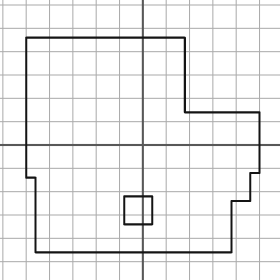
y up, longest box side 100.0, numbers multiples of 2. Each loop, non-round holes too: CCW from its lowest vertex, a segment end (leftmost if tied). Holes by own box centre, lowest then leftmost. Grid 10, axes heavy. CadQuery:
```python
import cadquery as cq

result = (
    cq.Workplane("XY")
    .moveTo(-46.0, -46.0)
    .lineTo(38.0, -46.0)
    .lineTo(38.0, -24.0)
    .lineTo(46.0, -24.0)
    .lineTo(46.0, -12.0)
    .lineTo(50.0, -12.0)
    .lineTo(50.0, 14.0)
    .lineTo(18.0, 14.0)
    .lineTo(18.0, 46.0)
    .lineTo(-50.0, 46.0)
    .lineTo(-50.0, -14.0)
    .lineTo(-46.0, -14.0)
    .close()
    .moveTo(-8.0, -34.0)
    .lineTo(4.0, -34.0)
    .lineTo(4.0, -22.0)
    .lineTo(-8.0, -22.0)
    .close()
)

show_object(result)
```